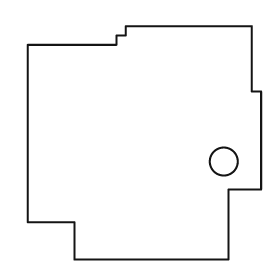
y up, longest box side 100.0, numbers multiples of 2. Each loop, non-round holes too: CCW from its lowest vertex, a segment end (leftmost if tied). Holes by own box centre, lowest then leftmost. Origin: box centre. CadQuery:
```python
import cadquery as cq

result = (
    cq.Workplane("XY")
    .moveTo(-30.0, -50.0)
    .lineTo(36.0, -50.0)
    .lineTo(36.0, -20.0)
    .lineTo(50.0, -20.0)
    .lineTo(50.0, 22.0)
    .lineTo(46.0, 22.0)
    .lineTo(46.0, 50.0)
    .lineTo(-8.0, 50.0)
    .lineTo(-8.0, 46.0)
    .lineTo(-12.0, 46.0)
    .lineTo(-12.0, 42.0)
    .lineTo(-50.0, 42.0)
    .lineTo(-50.0, -34.0)
    .lineTo(-30.0, -34.0)
    .close()
    .moveTo(34.0, -8.0)
    .circle(6.0)
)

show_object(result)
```